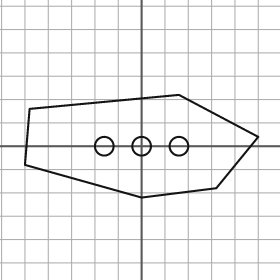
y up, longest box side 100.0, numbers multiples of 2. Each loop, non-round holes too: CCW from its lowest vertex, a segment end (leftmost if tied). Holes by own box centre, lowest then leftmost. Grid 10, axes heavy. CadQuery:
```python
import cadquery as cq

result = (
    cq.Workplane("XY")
    .moveTo(0.0, -22.0)
    .lineTo(32.0, -18.0)
    .lineTo(50.0, 4.0)
    .lineTo(16.0, 22.0)
    .lineTo(-48.0, 16.0)
    .lineTo(-50.0, -8.0)
    .close()
    .moveTo(-16.0, 0.0)
    .circle(4.0)
    .moveTo(0.0, 0.0)
    .circle(4.0)
    .moveTo(16.0, 0.0)
    .circle(4.0)
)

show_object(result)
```